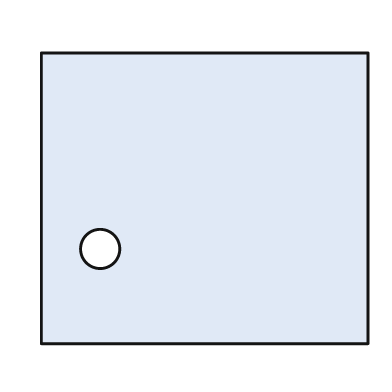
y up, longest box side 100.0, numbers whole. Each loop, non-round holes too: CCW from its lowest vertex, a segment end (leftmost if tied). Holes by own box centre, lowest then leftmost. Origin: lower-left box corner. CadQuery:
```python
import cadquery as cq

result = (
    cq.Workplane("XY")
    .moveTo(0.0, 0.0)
    .lineTo(100.0, 0.0)
    .lineTo(100.0, 89.0)
    .lineTo(0.0, 89.0)
    .close()
    .moveTo(18.0, 29.0)
    .circle(6.0)
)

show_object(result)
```